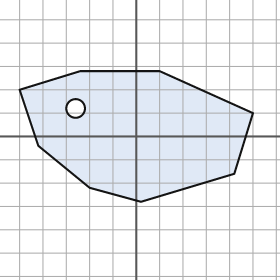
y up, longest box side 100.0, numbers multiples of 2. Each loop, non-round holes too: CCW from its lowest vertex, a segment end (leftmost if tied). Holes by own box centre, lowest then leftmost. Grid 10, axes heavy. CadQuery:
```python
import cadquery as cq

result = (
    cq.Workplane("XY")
    .moveTo(2.0, -28.0)
    .lineTo(42.0, -16.0)
    .lineTo(50.0, 10.0)
    .lineTo(10.0, 28.0)
    .lineTo(-24.0, 28.0)
    .lineTo(-50.0, 20.0)
    .lineTo(-42.0, -4.0)
    .lineTo(-20.0, -22.0)
    .close()
    .moveTo(-26.0, 12.0)
    .circle(4.0)
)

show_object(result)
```